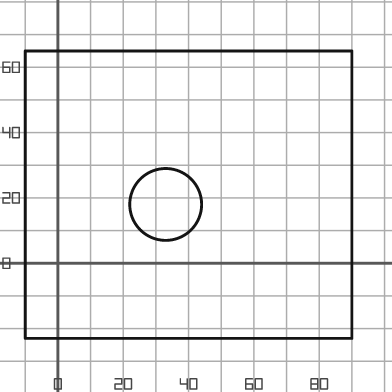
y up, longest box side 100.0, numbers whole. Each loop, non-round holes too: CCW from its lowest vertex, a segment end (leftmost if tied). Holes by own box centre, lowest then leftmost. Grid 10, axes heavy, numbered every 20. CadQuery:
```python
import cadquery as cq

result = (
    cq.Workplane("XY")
    .moveTo(-10.0, -23.0)
    .lineTo(90.0, -23.0)
    .lineTo(90.0, 65.0)
    .lineTo(-10.0, 65.0)
    .close()
    .moveTo(33.0, 18.0)
    .circle(11.0)
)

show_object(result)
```